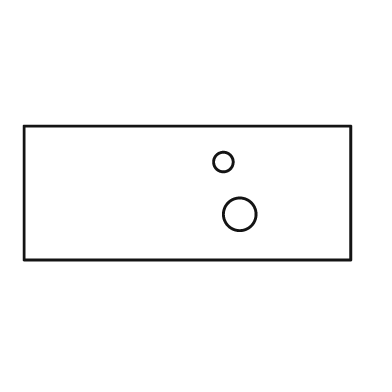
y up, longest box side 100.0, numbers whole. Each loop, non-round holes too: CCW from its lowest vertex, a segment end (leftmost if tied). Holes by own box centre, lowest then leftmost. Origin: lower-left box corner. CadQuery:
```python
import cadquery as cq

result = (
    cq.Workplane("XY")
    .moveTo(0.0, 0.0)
    .lineTo(100.0, 0.0)
    .lineTo(100.0, 41.0)
    .lineTo(0.0, 41.0)
    .close()
    .moveTo(66.0, 14.0)
    .circle(5.0)
    .moveTo(61.0, 30.0)
    .circle(3.0)
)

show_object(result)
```